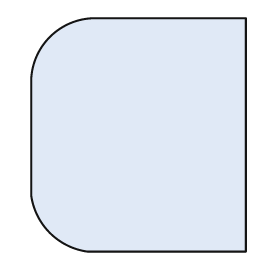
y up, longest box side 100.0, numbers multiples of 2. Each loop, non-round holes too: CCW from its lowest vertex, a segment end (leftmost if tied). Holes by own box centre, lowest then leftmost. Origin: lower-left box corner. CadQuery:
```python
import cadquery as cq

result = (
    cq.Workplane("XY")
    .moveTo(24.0, 0.0)
    .lineTo(92.0, 0.0)
    .lineTo(92.0, 100.0)
    .lineTo(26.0, 100.0)
    .threePointArc((8.0, 92.0), (0.0, 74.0))
    .lineTo(0.0, 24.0)
    .threePointArc((8.0, 8.0), (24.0, 0.0))
    .close()
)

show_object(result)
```